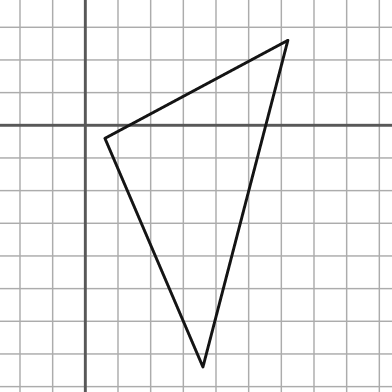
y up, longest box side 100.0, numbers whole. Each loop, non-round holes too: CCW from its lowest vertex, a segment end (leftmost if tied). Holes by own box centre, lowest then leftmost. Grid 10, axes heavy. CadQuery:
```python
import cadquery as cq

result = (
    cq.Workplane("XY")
    .moveTo(36.0, -74.0)
    .lineTo(62.0, 26.0)
    .lineTo(6.0, -4.0)
    .close()
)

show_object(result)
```